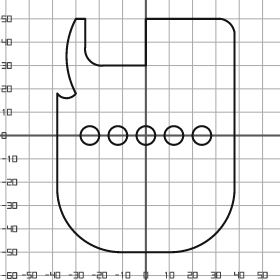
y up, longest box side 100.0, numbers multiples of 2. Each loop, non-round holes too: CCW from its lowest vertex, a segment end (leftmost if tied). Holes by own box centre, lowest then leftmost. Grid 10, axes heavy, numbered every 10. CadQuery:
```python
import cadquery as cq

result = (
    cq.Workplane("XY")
    .moveTo(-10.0, -50.0)
    .lineTo(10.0, -50.0)
    .threePointArc((30.0, -42.0), (38.0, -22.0))
    .lineTo(38.0, 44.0)
    .threePointArc((36.0, 48.0), (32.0, 50.0))
    .lineTo(0.0, 50.0)
    .lineTo(0.0, 30.0)
    .lineTo(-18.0, 30.0)
    .threePointArc((-24.0, 32.0), (-26.0, 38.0))
    .lineTo(-26.0, 50.0)
    .lineTo(-30.0, 50.0)
    .threePointArc((-34.0, 34.0), (-30.0, 18.0))
    .threePointArc((-34.0, 16.0), (-38.0, 18.0))
    .lineTo(-38.0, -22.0)
    .threePointArc((-30.0, -42.0), (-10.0, -50.0))
    .close()
    .moveTo(-24.0, 0.0)
    .circle(4.0)
    .moveTo(-12.0, 0.0)
    .circle(4.0)
    .moveTo(0.0, 0.0)
    .circle(4.0)
    .moveTo(12.0, 0.0)
    .circle(4.0)
    .moveTo(24.0, 0.0)
    .circle(4.0)
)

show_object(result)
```